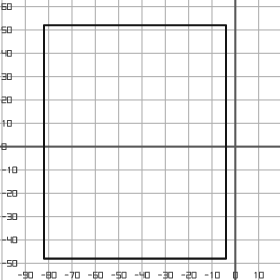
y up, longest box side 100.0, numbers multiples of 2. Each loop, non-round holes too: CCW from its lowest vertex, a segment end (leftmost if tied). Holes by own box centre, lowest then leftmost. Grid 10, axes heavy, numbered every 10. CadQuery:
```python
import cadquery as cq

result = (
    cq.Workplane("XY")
    .moveTo(-82.0, -48.0)
    .lineTo(-4.0, -48.0)
    .lineTo(-4.0, 52.0)
    .lineTo(-82.0, 52.0)
    .close()
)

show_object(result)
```